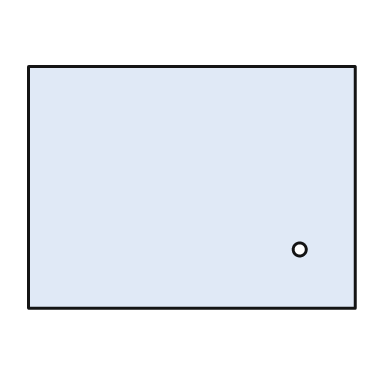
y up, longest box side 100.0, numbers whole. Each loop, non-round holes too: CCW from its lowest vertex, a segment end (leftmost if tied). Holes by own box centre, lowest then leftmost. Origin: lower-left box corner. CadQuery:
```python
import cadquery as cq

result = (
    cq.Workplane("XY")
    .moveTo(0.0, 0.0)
    .lineTo(100.0, 0.0)
    .lineTo(100.0, 74.0)
    .lineTo(0.0, 74.0)
    .close()
    .moveTo(83.0, 18.0)
    .circle(2.0)
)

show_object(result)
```